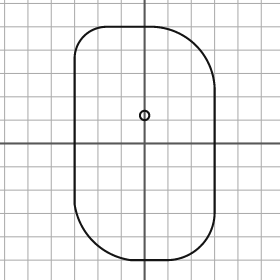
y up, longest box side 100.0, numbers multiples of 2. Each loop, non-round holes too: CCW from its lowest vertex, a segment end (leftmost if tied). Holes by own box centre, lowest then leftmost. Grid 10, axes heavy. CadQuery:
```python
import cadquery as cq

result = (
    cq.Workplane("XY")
    .moveTo(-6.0, -50.0)
    .lineTo(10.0, -50.0)
    .threePointArc((24.0, -44.0), (30.0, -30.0))
    .lineTo(30.0, 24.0)
    .threePointArc((22.0, 42.0), (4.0, 50.0))
    .lineTo(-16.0, 50.0)
    .threePointArc((-26.0, 46.0), (-30.0, 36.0))
    .lineTo(-30.0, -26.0)
    .threePointArc((-22.0, -42.0), (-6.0, -50.0))
    .close()
    .moveTo(0.0, 12.0)
    .circle(2.0)
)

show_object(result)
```